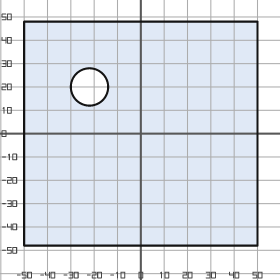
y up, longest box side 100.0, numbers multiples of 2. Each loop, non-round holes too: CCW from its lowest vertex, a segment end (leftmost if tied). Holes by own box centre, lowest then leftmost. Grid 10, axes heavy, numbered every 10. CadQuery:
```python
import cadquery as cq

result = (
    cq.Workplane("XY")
    .moveTo(-50.0, -48.0)
    .lineTo(50.0, -48.0)
    .lineTo(50.0, 48.0)
    .lineTo(-50.0, 48.0)
    .close()
    .moveTo(-22.0, 20.0)
    .circle(8.0)
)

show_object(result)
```